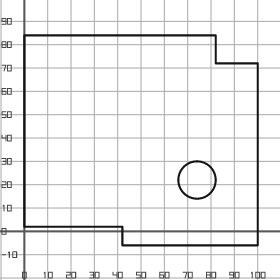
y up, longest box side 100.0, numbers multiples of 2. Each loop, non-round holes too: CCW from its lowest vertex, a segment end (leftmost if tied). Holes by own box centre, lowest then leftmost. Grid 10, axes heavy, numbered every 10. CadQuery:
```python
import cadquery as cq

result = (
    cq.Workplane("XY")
    .moveTo(42.0, -6.0)
    .lineTo(100.0, -6.0)
    .lineTo(100.0, 72.0)
    .lineTo(82.0, 72.0)
    .lineTo(82.0, 84.0)
    .lineTo(0.0, 84.0)
    .lineTo(0.0, 2.0)
    .lineTo(42.0, 2.0)
    .close()
    .moveTo(74.0, 22.0)
    .circle(8.0)
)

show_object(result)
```